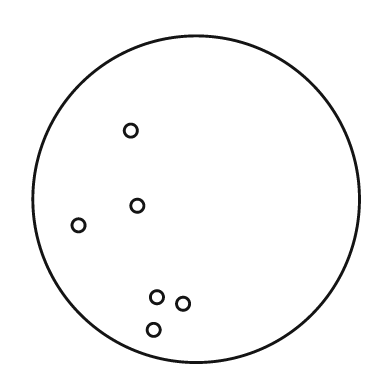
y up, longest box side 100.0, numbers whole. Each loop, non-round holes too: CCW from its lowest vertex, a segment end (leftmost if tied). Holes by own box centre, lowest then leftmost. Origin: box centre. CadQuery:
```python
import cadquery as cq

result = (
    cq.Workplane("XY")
    .moveTo(0.0, 0.0)
    .circle(50.0)
    .moveTo(-13.0, -40.0)
    .circle(2.0)
    .moveTo(-4.0, -32.0)
    .circle(2.0)
    .moveTo(-12.0, -30.0)
    .circle(2.0)
    .moveTo(-36.0, -8.0)
    .circle(2.0)
    .moveTo(-18.0, -2.0)
    .circle(2.0)
    .moveTo(-20.0, 21.0)
    .circle(2.0)
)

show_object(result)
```